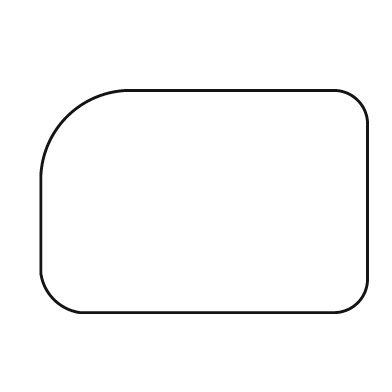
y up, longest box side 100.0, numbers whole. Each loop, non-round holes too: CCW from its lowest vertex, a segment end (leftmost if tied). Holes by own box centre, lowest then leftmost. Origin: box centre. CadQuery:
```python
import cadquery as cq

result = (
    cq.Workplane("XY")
    .moveTo(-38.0, -34.0)
    .lineTo(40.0, -34.0)
    .threePointArc((47.0, -31.0), (50.0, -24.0))
    .lineTo(50.0, 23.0)
    .threePointArc((47.0, 31.0), (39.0, 34.0))
    .lineTo(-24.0, 34.0)
    .threePointArc((-42.0, 26.0), (-50.0, 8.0))
    .lineTo(-50.0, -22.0)
    .threePointArc((-46.0, -30.0), (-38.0, -34.0))
    .close()
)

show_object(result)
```